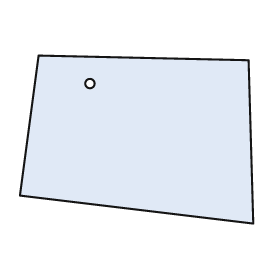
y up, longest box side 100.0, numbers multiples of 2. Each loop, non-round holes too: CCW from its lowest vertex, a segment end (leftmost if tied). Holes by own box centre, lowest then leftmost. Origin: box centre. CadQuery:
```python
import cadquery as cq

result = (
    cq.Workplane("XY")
    .moveTo(50.0, -36.0)
    .lineTo(48.0, 34.0)
    .lineTo(-42.0, 36.0)
    .lineTo(-50.0, -24.0)
    .close()
    .moveTo(-20.0, 24.0)
    .circle(2.0)
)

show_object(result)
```